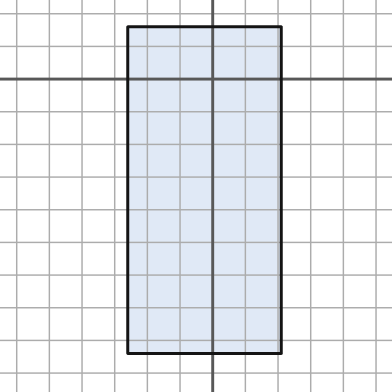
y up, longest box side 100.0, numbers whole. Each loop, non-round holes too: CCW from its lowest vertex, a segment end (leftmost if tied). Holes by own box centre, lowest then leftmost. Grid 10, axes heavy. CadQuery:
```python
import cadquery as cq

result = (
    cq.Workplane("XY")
    .moveTo(-26.0, -84.0)
    .lineTo(21.0, -84.0)
    .lineTo(21.0, 16.0)
    .lineTo(-26.0, 16.0)
    .close()
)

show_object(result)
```